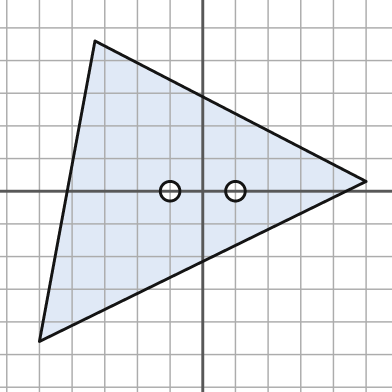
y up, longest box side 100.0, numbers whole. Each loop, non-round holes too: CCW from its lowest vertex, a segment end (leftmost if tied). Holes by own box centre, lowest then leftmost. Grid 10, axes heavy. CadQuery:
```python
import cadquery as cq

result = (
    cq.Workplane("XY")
    .moveTo(-50.0, -46.0)
    .lineTo(50.0, 3.0)
    .lineTo(-33.0, 46.0)
    .close()
    .moveTo(-10.0, 0.0)
    .circle(3.0)
    .moveTo(10.0, 0.0)
    .circle(3.0)
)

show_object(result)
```